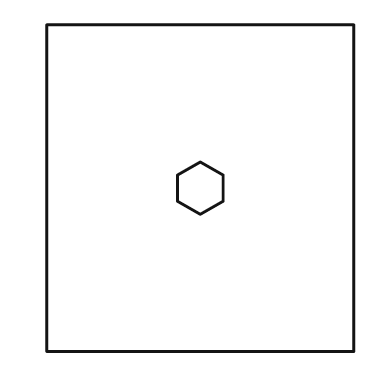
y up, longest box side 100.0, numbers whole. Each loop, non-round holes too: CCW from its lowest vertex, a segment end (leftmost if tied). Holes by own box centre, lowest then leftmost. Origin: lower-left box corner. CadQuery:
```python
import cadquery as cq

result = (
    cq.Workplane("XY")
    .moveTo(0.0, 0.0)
    .lineTo(94.0, 0.0)
    .lineTo(94.0, 100.0)
    .lineTo(0.0, 100.0)
    .close()
    .moveTo(47.0, 42.0)
    .lineTo(54.0, 46.0)
    .lineTo(54.0, 54.0)
    .lineTo(47.0, 58.0)
    .lineTo(40.0, 54.0)
    .lineTo(40.0, 46.0)
    .close()
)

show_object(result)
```